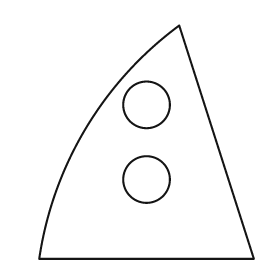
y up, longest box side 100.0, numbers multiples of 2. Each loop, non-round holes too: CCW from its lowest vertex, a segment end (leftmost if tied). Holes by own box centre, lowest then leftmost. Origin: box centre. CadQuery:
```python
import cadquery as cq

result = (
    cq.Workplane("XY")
    .moveTo(-46.0, -50.0)
    .lineTo(46.0, -50.0)
    .lineTo(14.0, 50.0)
    .threePointArc((-26.0, 6.0), (-46.0, -50.0))
    .close()
    .moveTo(0.0, -16.0)
    .circle(10.0)
    .moveTo(0.0, 16.0)
    .circle(10.0)
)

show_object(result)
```